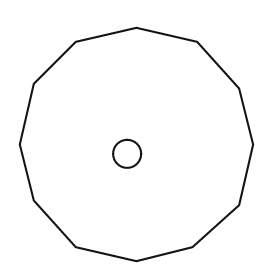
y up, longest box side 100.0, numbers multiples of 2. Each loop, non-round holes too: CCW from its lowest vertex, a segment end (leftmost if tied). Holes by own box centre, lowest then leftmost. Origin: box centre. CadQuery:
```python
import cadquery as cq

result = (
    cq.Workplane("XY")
    .moveTo(0.0, -50.0)
    .lineTo(24.0, -44.0)
    .lineTo(44.0, -26.0)
    .lineTo(50.0, 0.0)
    .lineTo(44.0, 24.0)
    .lineTo(26.0, 44.0)
    .lineTo(0.0, 50.0)
    .lineTo(-26.0, 44.0)
    .lineTo(-44.0, 26.0)
    .lineTo(-50.0, 0.0)
    .lineTo(-44.0, -24.0)
    .lineTo(-26.0, -44.0)
    .close()
    .moveTo(-4.0, -4.0)
    .circle(6.0)
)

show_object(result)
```